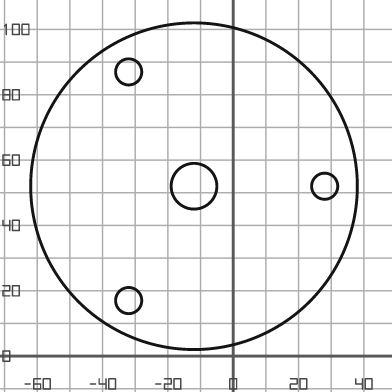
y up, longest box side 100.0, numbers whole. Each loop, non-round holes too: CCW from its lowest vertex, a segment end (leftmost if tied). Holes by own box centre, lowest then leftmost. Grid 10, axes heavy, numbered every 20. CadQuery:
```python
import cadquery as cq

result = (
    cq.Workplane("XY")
    .moveTo(-12.0, 52.0)
    .circle(50.0)
    .moveTo(-32.0, 17.0)
    .circle(4.0)
    .moveTo(-12.0, 52.0)
    .circle(7.0)
    .moveTo(28.0, 52.0)
    .circle(4.0)
    .moveTo(-32.0, 87.0)
    .circle(4.0)
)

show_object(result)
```